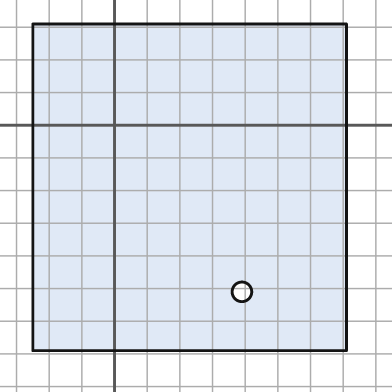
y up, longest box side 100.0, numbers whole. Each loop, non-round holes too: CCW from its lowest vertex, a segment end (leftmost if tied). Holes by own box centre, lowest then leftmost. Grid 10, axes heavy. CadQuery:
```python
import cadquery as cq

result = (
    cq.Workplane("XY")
    .moveTo(-25.0, -69.0)
    .lineTo(71.0, -69.0)
    .lineTo(71.0, 31.0)
    .lineTo(-25.0, 31.0)
    .close()
    .moveTo(39.0, -51.0)
    .circle(3.0)
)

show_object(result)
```